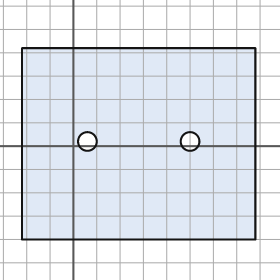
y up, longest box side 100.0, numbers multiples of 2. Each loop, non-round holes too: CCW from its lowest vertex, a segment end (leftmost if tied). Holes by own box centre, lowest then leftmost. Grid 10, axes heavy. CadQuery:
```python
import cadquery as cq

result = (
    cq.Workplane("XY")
    .moveTo(-22.0, -40.0)
    .lineTo(78.0, -40.0)
    .lineTo(78.0, 42.0)
    .lineTo(-22.0, 42.0)
    .close()
    .moveTo(6.0, 2.0)
    .circle(4.0)
    .moveTo(50.0, 2.0)
    .circle(4.0)
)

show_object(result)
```